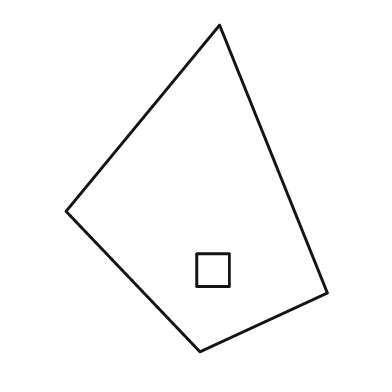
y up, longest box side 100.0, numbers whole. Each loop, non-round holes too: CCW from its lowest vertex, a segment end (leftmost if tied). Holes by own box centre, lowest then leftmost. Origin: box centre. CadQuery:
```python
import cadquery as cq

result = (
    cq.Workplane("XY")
    .moveTo(1.0, -50.0)
    .lineTo(40.0, -32.0)
    .lineTo(7.0, 50.0)
    .lineTo(-40.0, -7.0)
    .close()
    .moveTo(0.0, -30.0)
    .lineTo(10.0, -30.0)
    .lineTo(10.0, -20.0)
    .lineTo(0.0, -20.0)
    .close()
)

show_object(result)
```